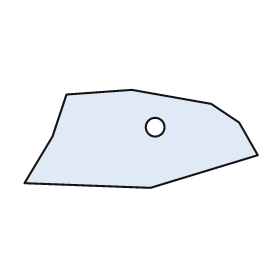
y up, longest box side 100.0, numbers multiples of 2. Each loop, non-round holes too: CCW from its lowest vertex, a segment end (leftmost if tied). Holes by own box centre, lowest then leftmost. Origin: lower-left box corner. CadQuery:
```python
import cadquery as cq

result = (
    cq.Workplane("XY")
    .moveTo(54.0, 0.0)
    .lineTo(100.0, 14.0)
    .lineTo(92.0, 28.0)
    .lineTo(80.0, 36.0)
    .lineTo(46.0, 42.0)
    .lineTo(18.0, 40.0)
    .lineTo(12.0, 22.0)
    .lineTo(0.0, 2.0)
    .close()
    .moveTo(56.0, 26.0)
    .circle(4.0)
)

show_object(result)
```